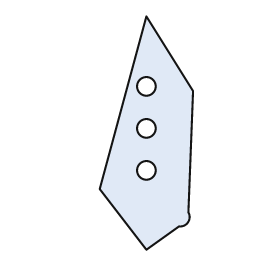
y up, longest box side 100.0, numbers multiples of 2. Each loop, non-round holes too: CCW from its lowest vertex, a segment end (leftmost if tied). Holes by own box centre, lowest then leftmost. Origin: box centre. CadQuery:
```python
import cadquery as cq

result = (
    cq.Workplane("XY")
    .moveTo(0.0, -50.0)
    .lineTo(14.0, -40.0)
    .threePointArc((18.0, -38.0), (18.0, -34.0))
    .lineTo(20.0, 18.0)
    .lineTo(0.0, 50.0)
    .lineTo(-20.0, -24.0)
    .close()
    .moveTo(0.0, -16.0)
    .circle(4.0)
    .moveTo(0.0, 2.0)
    .circle(4.0)
    .moveTo(0.0, 20.0)
    .circle(4.0)
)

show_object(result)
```